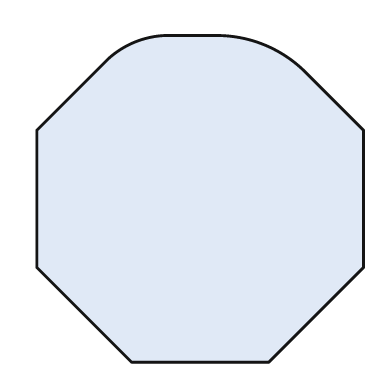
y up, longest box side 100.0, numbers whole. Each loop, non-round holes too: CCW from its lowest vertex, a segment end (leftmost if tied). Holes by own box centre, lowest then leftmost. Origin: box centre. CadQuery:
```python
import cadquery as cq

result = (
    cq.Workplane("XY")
    .moveTo(-21.0, -50.0)
    .lineTo(21.0, -50.0)
    .lineTo(50.0, -21.0)
    .lineTo(50.0, 21.0)
    .lineTo(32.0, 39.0)
    .threePointArc((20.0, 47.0), (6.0, 50.0))
    .lineTo(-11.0, 50.0)
    .threePointArc((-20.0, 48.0), (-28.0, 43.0))
    .lineTo(-50.0, 21.0)
    .lineTo(-50.0, -21.0)
    .close()
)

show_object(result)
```